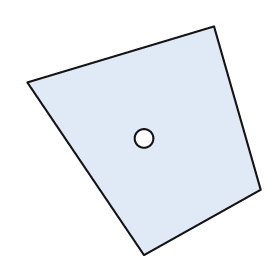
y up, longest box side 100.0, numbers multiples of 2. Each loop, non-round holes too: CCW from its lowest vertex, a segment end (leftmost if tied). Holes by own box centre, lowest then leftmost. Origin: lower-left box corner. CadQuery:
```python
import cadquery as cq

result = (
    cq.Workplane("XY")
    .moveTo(50.0, 0.0)
    .lineTo(100.0, 28.0)
    .lineTo(80.0, 98.0)
    .lineTo(0.0, 74.0)
    .close()
    .moveTo(50.0, 50.0)
    .circle(4.0)
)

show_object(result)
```